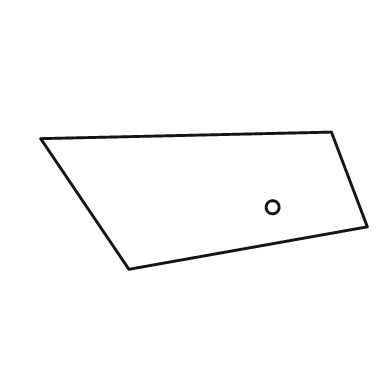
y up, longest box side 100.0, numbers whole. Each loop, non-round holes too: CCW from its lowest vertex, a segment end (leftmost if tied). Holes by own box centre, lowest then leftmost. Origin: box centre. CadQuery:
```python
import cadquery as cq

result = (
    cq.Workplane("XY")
    .moveTo(-23.0, -21.0)
    .lineTo(50.0, -8.0)
    .lineTo(39.0, 21.0)
    .lineTo(-50.0, 19.0)
    .close()
    .moveTo(21.0, -2.0)
    .circle(2.0)
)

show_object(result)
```